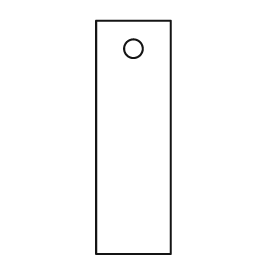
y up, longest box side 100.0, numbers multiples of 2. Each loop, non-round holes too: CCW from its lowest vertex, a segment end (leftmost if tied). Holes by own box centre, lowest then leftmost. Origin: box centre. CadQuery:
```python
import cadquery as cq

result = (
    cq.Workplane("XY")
    .moveTo(-16.0, -50.0)
    .lineTo(16.0, -50.0)
    .lineTo(16.0, 50.0)
    .lineTo(-16.0, 50.0)
    .close()
    .moveTo(0.0, 38.0)
    .circle(4.0)
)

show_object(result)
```